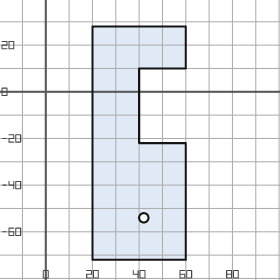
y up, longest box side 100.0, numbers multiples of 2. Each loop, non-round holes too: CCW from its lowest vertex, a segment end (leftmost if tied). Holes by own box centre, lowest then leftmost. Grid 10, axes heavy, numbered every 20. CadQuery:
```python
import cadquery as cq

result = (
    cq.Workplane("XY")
    .moveTo(20.0, -72.0)
    .lineTo(60.0, -72.0)
    .lineTo(60.0, -22.0)
    .lineTo(40.0, -22.0)
    .lineTo(40.0, 10.0)
    .lineTo(60.0, 10.0)
    .lineTo(60.0, 28.0)
    .lineTo(20.0, 28.0)
    .close()
    .moveTo(42.0, -54.0)
    .circle(2.0)
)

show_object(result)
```